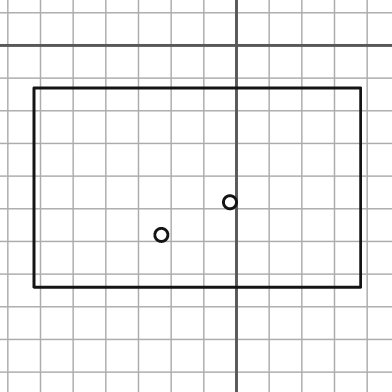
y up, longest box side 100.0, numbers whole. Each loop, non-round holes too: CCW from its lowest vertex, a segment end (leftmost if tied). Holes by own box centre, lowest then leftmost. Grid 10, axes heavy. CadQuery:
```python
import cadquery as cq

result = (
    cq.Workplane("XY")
    .moveTo(-62.0, -74.0)
    .lineTo(38.0, -74.0)
    .lineTo(38.0, -13.0)
    .lineTo(-62.0, -13.0)
    .close()
    .moveTo(-23.0, -58.0)
    .circle(2.0)
    .moveTo(-2.0, -48.0)
    .circle(2.0)
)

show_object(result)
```